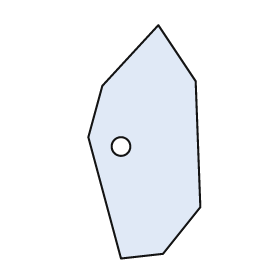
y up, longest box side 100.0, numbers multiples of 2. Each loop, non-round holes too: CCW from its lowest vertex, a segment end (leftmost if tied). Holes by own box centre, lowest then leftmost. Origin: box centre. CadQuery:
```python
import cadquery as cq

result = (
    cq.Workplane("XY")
    .moveTo(-10.0, -50.0)
    .lineTo(8.0, -48.0)
    .lineTo(24.0, -28.0)
    .lineTo(22.0, 26.0)
    .lineTo(6.0, 50.0)
    .lineTo(-18.0, 24.0)
    .lineTo(-24.0, 2.0)
    .close()
    .moveTo(-10.0, -2.0)
    .circle(4.0)
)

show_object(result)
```